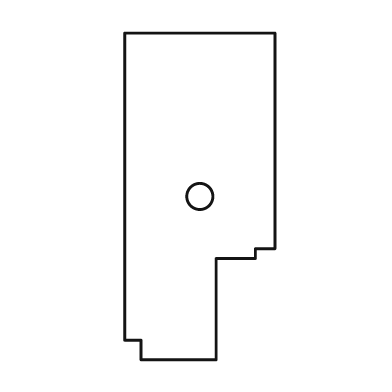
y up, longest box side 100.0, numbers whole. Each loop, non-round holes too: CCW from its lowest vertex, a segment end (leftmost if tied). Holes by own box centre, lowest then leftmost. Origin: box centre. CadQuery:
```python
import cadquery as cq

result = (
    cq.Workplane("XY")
    .moveTo(-18.0, -50.0)
    .lineTo(5.0, -50.0)
    .lineTo(5.0, -19.0)
    .lineTo(17.0, -19.0)
    .lineTo(17.0, -16.0)
    .lineTo(23.0, -16.0)
    .lineTo(23.0, 50.0)
    .lineTo(-23.0, 50.0)
    .lineTo(-23.0, -44.0)
    .lineTo(-18.0, -44.0)
    .close()
    .moveTo(0.0, 0.0)
    .circle(4.0)
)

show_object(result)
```